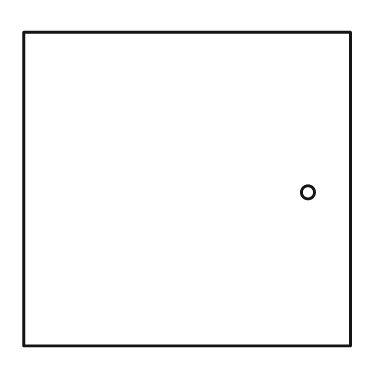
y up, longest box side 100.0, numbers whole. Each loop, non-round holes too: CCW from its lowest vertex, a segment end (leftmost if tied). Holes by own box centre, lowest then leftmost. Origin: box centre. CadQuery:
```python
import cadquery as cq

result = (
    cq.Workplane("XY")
    .moveTo(-50.0, -48.0)
    .lineTo(50.0, -48.0)
    .lineTo(50.0, 48.0)
    .lineTo(-50.0, 48.0)
    .close()
    .moveTo(37.0, -1.0)
    .circle(2.0)
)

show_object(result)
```